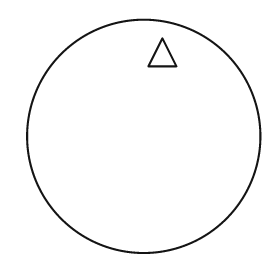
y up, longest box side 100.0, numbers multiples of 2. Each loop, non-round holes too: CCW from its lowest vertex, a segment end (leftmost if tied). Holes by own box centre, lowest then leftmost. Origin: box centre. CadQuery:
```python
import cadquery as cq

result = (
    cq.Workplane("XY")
    .moveTo(0.0, 0.0)
    .circle(50.0)
    .moveTo(2.0, 30.0)
    .lineTo(14.0, 30.0)
    .lineTo(8.0, 42.0)
    .close()
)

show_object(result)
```